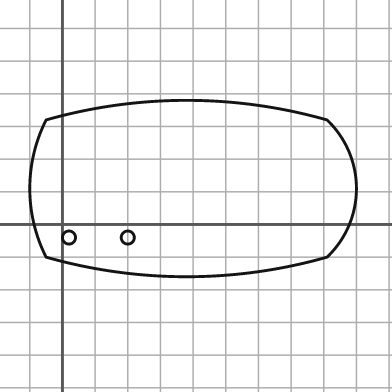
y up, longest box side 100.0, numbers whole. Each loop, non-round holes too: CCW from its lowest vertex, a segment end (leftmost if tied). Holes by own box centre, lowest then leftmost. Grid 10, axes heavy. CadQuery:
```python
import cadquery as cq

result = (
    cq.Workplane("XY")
    .moveTo(-5.0, -10.0)
    .threePointArc((38.0, -16.0), (81.0, -10.0))
    .threePointArc((90.0, 11.0), (81.0, 32.0))
    .threePointArc((38.0, 38.0), (-5.0, 32.0))
    .threePointArc((-10.0, 11.0), (-5.0, -10.0))
    .close()
    .moveTo(2.0, -4.0)
    .circle(2.0)
    .moveTo(20.0, -4.0)
    .circle(2.0)
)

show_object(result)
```